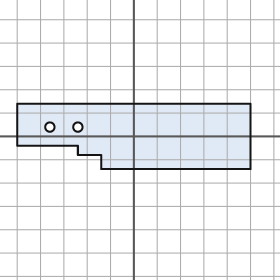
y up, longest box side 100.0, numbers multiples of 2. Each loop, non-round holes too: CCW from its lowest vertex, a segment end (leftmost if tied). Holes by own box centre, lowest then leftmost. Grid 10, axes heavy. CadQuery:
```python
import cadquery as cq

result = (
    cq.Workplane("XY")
    .moveTo(-14.0, -14.0)
    .lineTo(50.0, -14.0)
    .lineTo(50.0, 14.0)
    .lineTo(-50.0, 14.0)
    .lineTo(-50.0, -4.0)
    .lineTo(-24.0, -4.0)
    .lineTo(-24.0, -8.0)
    .lineTo(-14.0, -8.0)
    .close()
    .moveTo(-36.0, 4.0)
    .circle(2.0)
    .moveTo(-24.0, 4.0)
    .circle(2.0)
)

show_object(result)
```